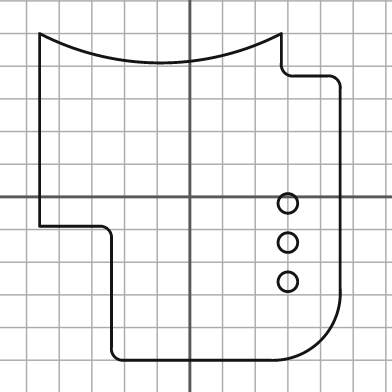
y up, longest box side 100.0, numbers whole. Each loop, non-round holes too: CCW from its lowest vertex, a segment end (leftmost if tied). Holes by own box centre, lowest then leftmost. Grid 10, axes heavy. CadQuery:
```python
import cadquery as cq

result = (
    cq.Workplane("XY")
    .moveTo(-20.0, -50.0)
    .lineTo(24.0, -50.0)
    .threePointArc((40.0, -44.0), (46.0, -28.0))
    .lineTo(46.0, 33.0)
    .threePointArc((45.0, 36.0), (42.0, 37.0))
    .lineTo(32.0, 37.0)
    .threePointArc((29.0, 38.0), (28.0, 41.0))
    .lineTo(28.0, 50.0)
    .threePointArc((-9.0, 41.0), (-46.0, 50.0))
    .lineTo(-46.0, -9.0)
    .lineTo(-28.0, -9.0)
    .threePointArc((-25.0, -10.0), (-24.0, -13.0))
    .lineTo(-24.0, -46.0)
    .threePointArc((-23.0, -49.0), (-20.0, -50.0))
    .close()
    .moveTo(30.0, -26.0)
    .circle(3.0)
    .moveTo(30.0, -14.0)
    .circle(3.0)
    .moveTo(30.0, -2.0)
    .circle(3.0)
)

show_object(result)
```